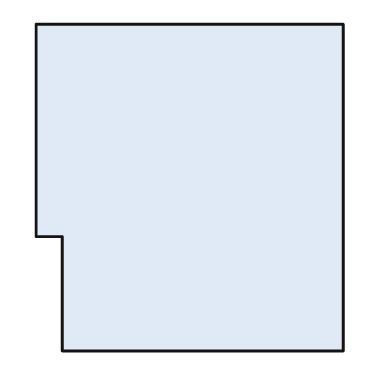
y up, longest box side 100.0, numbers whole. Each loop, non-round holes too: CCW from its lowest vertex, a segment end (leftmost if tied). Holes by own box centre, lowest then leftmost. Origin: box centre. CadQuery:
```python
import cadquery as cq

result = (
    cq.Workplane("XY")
    .moveTo(-39.0, -50.0)
    .lineTo(47.0, -50.0)
    .lineTo(47.0, 50.0)
    .lineTo(-47.0, 50.0)
    .lineTo(-47.0, -15.0)
    .lineTo(-39.0, -15.0)
    .close()
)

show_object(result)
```